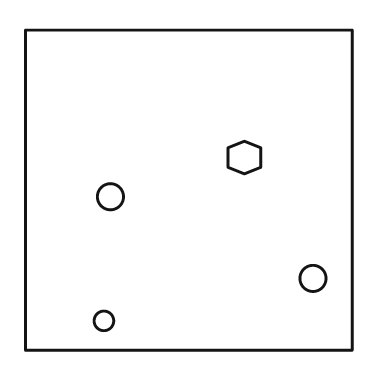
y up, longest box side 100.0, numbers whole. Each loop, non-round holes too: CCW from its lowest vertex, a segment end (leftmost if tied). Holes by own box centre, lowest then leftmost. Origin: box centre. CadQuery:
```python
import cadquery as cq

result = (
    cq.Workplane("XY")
    .moveTo(-50.0, -49.0)
    .lineTo(50.0, -49.0)
    .lineTo(50.0, 49.0)
    .lineTo(-50.0, 49.0)
    .close()
    .moveTo(-26.0, -40.0)
    .circle(3.0)
    .moveTo(38.0, -27.0)
    .circle(4.0)
    .moveTo(-24.0, -2.0)
    .circle(4.0)
    .moveTo(17.0, 5.0)
    .lineTo(22.0, 7.0)
    .lineTo(22.0, 13.0)
    .lineTo(17.0, 15.0)
    .lineTo(12.0, 13.0)
    .lineTo(12.0, 7.0)
    .close()
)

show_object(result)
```